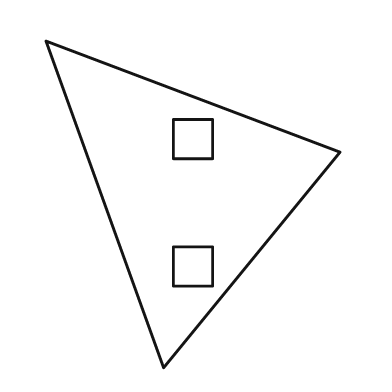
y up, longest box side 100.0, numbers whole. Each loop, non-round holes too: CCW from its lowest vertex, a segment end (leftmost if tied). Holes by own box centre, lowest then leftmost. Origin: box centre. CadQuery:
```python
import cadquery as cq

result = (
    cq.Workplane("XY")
    .moveTo(-9.0, -50.0)
    .lineTo(45.0, 16.0)
    .lineTo(-45.0, 50.0)
    .close()
    .moveTo(-6.0, -25.0)
    .lineTo(6.0, -25.0)
    .lineTo(6.0, -13.0)
    .lineTo(-6.0, -13.0)
    .close()
    .moveTo(-6.0, 14.0)
    .lineTo(6.0, 14.0)
    .lineTo(6.0, 26.0)
    .lineTo(-6.0, 26.0)
    .close()
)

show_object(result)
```